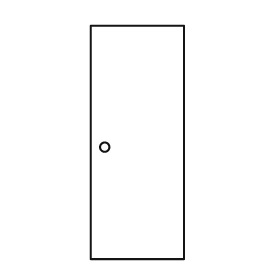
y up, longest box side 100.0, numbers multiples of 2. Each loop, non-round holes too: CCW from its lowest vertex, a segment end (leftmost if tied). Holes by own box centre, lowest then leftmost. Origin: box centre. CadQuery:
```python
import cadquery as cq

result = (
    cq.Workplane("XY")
    .moveTo(-20.0, -50.0)
    .lineTo(20.0, -50.0)
    .lineTo(20.0, 50.0)
    .lineTo(-20.0, 50.0)
    .close()
    .moveTo(-14.0, -2.0)
    .circle(2.0)
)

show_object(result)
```